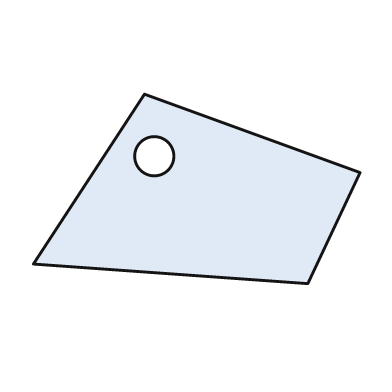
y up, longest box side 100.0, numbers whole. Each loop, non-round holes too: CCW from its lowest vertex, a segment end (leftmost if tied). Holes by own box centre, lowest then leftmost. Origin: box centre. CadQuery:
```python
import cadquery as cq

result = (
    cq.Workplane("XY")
    .moveTo(34.0, -29.0)
    .lineTo(50.0, 5.0)
    .lineTo(-16.0, 29.0)
    .lineTo(-50.0, -23.0)
    .close()
    .moveTo(-13.0, 10.0)
    .circle(6.0)
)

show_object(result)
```